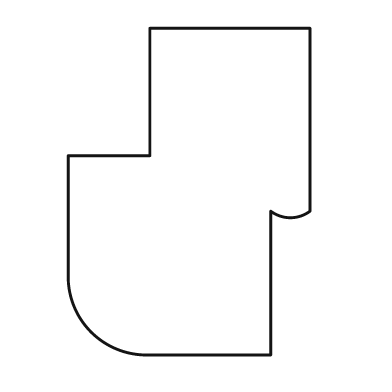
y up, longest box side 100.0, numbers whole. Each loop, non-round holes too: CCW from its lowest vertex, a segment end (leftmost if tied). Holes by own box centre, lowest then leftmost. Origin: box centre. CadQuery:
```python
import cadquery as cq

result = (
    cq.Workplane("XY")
    .moveTo(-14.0, -50.0)
    .lineTo(25.0, -50.0)
    .lineTo(25.0, -6.0)
    .threePointArc((31.0, -8.0), (37.0, -6.0))
    .lineTo(37.0, 50.0)
    .lineTo(-12.0, 50.0)
    .lineTo(-12.0, 11.0)
    .lineTo(-37.0, 11.0)
    .lineTo(-37.0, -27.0)
    .threePointArc((-30.0, -43.0), (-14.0, -50.0))
    .close()
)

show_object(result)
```